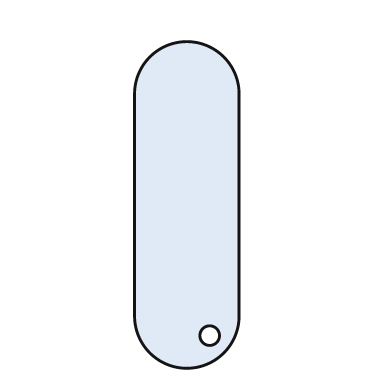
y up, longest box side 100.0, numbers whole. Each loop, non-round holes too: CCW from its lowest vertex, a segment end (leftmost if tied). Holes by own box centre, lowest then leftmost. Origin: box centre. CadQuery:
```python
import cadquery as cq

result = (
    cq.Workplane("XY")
    .moveTo(-16.0, -34.0)
    .threePointArc((0.0, -50.0), (16.0, -34.0))
    .lineTo(16.0, 34.0)
    .threePointArc((0.0, 50.0), (-16.0, 34.0))
    .close()
    .moveTo(7.0, -40.0)
    .circle(3.0)
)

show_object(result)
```